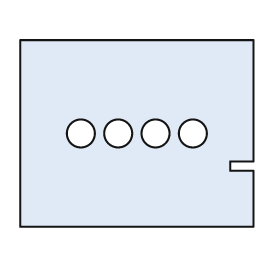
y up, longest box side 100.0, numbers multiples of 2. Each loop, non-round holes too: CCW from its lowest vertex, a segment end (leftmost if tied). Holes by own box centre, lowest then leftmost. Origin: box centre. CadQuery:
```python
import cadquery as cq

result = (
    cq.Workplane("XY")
    .moveTo(-50.0, -40.0)
    .lineTo(50.0, -40.0)
    .lineTo(50.0, -16.0)
    .lineTo(40.0, -16.0)
    .lineTo(40.0, -12.0)
    .lineTo(50.0, -12.0)
    .lineTo(50.0, 40.0)
    .lineTo(-50.0, 40.0)
    .close()
    .moveTo(-24.0, 0.0)
    .circle(6.0)
    .moveTo(-8.0, 0.0)
    .circle(6.0)
    .moveTo(8.0, 0.0)
    .circle(6.0)
    .moveTo(24.0, 0.0)
    .circle(6.0)
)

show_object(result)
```